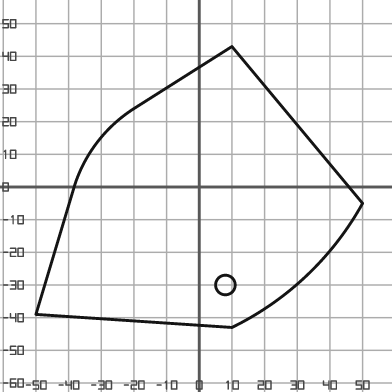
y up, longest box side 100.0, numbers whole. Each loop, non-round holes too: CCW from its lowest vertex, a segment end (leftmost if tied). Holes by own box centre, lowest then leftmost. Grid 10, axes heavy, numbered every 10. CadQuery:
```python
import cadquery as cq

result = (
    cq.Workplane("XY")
    .moveTo(10.0, -43.0)
    .threePointArc((33.0, -27.0), (50.0, -5.0))
    .lineTo(10.0, 43.0)
    .lineTo(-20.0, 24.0)
    .threePointArc((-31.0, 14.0), (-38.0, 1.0))
    .lineTo(-50.0, -39.0)
    .close()
    .moveTo(8.0, -30.0)
    .circle(3.0)
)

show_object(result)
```